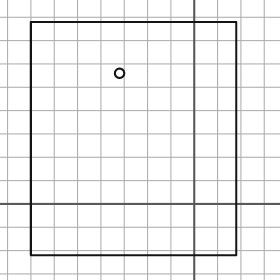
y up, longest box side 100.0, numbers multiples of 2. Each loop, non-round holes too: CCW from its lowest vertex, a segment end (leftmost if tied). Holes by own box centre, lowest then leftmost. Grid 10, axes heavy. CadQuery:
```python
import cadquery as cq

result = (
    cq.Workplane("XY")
    .moveTo(-70.0, -22.0)
    .lineTo(18.0, -22.0)
    .lineTo(18.0, 78.0)
    .lineTo(-70.0, 78.0)
    .close()
    .moveTo(-32.0, 56.0)
    .circle(2.0)
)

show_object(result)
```